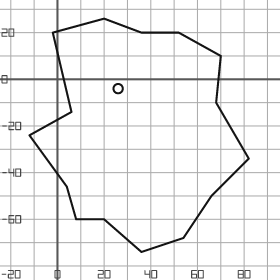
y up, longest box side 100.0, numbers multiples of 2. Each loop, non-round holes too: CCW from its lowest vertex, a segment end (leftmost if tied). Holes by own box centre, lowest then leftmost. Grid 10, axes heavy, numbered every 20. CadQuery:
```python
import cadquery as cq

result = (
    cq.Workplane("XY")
    .moveTo(36.0, -74.0)
    .lineTo(54.0, -68.0)
    .lineTo(66.0, -50.0)
    .lineTo(82.0, -34.0)
    .lineTo(68.0, -10.0)
    .lineTo(70.0, 10.0)
    .lineTo(52.0, 20.0)
    .lineTo(36.0, 20.0)
    .lineTo(20.0, 26.0)
    .lineTo(-2.0, 20.0)
    .lineTo(6.0, -14.0)
    .lineTo(-12.0, -24.0)
    .lineTo(4.0, -46.0)
    .lineTo(8.0, -60.0)
    .lineTo(20.0, -60.0)
    .close()
    .moveTo(26.0, -4.0)
    .circle(2.0)
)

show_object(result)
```